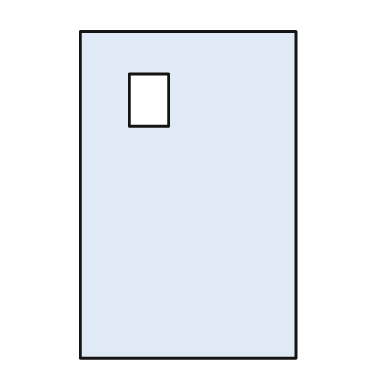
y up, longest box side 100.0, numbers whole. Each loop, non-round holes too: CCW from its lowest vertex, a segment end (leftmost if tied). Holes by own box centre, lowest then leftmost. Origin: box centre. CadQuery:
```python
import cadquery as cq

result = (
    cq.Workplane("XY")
    .moveTo(-33.0, -50.0)
    .lineTo(33.0, -50.0)
    .lineTo(33.0, 50.0)
    .lineTo(-33.0, 50.0)
    .close()
    .moveTo(-18.0, 21.0)
    .lineTo(-6.0, 21.0)
    .lineTo(-6.0, 37.0)
    .lineTo(-18.0, 37.0)
    .close()
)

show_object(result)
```